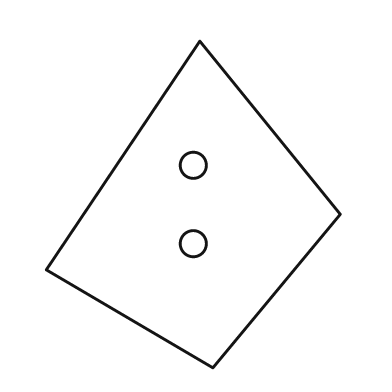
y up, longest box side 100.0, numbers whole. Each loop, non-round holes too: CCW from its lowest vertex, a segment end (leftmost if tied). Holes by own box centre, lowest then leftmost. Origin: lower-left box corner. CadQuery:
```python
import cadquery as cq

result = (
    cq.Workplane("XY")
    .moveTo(51.0, 0.0)
    .lineTo(90.0, 47.0)
    .lineTo(47.0, 100.0)
    .lineTo(0.0, 30.0)
    .close()
    .moveTo(45.0, 38.0)
    .circle(4.0)
    .moveTo(45.0, 62.0)
    .circle(4.0)
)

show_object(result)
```